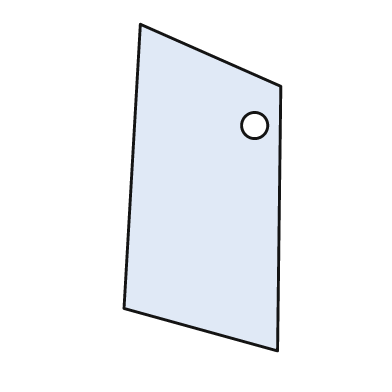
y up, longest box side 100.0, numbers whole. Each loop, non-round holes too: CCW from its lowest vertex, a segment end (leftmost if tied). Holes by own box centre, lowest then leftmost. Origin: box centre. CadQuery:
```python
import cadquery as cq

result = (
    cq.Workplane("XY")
    .moveTo(23.0, -50.0)
    .lineTo(24.0, 31.0)
    .lineTo(-19.0, 50.0)
    .lineTo(-24.0, -37.0)
    .close()
    .moveTo(16.0, 19.0)
    .circle(4.0)
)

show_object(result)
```